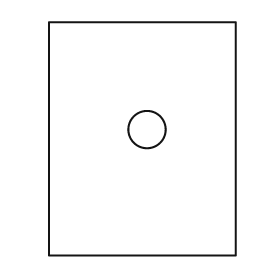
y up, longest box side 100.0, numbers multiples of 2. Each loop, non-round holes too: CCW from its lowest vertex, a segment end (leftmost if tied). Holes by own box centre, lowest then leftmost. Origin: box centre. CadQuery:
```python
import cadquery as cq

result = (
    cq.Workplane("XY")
    .moveTo(-40.0, -50.0)
    .lineTo(40.0, -50.0)
    .lineTo(40.0, 50.0)
    .lineTo(-40.0, 50.0)
    .close()
    .moveTo(2.0, 4.0)
    .circle(8.0)
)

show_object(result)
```